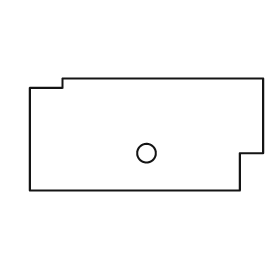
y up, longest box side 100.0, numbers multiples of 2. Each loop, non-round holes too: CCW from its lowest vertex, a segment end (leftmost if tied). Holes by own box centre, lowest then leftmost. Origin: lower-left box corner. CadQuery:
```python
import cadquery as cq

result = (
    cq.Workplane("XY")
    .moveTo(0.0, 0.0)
    .lineTo(90.0, 0.0)
    .lineTo(90.0, 16.0)
    .lineTo(100.0, 16.0)
    .lineTo(100.0, 48.0)
    .lineTo(14.0, 48.0)
    .lineTo(14.0, 44.0)
    .lineTo(0.0, 44.0)
    .close()
    .moveTo(50.0, 16.0)
    .circle(4.0)
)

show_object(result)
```